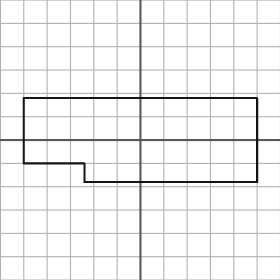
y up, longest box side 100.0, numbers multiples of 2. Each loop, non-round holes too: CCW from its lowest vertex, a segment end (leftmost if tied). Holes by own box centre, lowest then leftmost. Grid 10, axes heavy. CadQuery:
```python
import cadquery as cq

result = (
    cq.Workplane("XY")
    .moveTo(-24.0, -18.0)
    .lineTo(50.0, -18.0)
    .lineTo(50.0, 18.0)
    .lineTo(-50.0, 18.0)
    .lineTo(-50.0, -10.0)
    .lineTo(-24.0, -10.0)
    .close()
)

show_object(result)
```